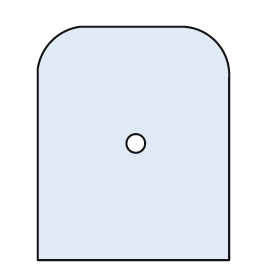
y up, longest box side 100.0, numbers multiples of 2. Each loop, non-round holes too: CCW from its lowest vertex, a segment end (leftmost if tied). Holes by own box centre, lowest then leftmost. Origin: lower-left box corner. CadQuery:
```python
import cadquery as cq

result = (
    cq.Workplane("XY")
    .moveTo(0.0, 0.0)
    .lineTo(82.0, 0.0)
    .lineTo(82.0, 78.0)
    .threePointArc((76.0, 94.0), (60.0, 100.0))
    .lineTo(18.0, 100.0)
    .threePointArc((6.0, 94.0), (0.0, 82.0))
    .close()
    .moveTo(42.0, 50.0)
    .circle(4.0)
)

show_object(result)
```